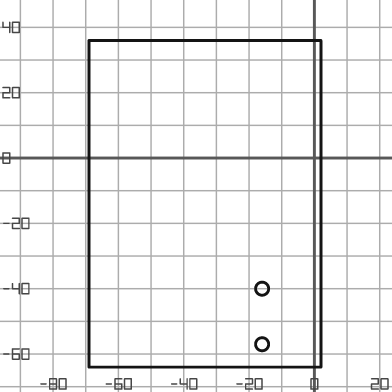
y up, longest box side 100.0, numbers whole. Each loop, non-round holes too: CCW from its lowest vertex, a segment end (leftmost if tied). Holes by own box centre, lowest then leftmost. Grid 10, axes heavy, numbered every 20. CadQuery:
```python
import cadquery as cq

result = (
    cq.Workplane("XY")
    .moveTo(-69.0, -64.0)
    .lineTo(2.0, -64.0)
    .lineTo(2.0, 36.0)
    .lineTo(-69.0, 36.0)
    .close()
    .moveTo(-16.0, -57.0)
    .circle(2.0)
    .moveTo(-16.0, -40.0)
    .circle(2.0)
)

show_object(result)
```